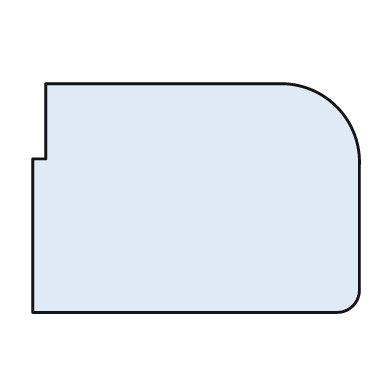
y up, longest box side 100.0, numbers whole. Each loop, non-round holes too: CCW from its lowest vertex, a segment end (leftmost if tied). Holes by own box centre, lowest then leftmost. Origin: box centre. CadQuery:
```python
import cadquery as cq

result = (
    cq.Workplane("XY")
    .moveTo(-50.0, -35.0)
    .lineTo(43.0, -35.0)
    .threePointArc((48.0, -33.0), (50.0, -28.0))
    .lineTo(50.0, 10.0)
    .threePointArc((43.0, 28.0), (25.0, 35.0))
    .lineTo(-46.0, 35.0)
    .lineTo(-46.0, 12.0)
    .lineTo(-50.0, 12.0)
    .close()
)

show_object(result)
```